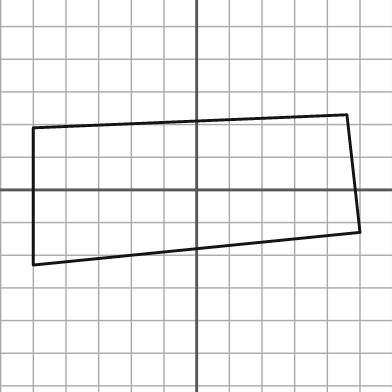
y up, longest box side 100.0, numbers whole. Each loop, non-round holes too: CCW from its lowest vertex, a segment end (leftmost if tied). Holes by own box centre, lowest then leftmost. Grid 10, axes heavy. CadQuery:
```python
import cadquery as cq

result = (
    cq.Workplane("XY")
    .moveTo(-50.0, -23.0)
    .lineTo(50.0, -13.0)
    .lineTo(46.0, 23.0)
    .lineTo(-50.0, 19.0)
    .close()
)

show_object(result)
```